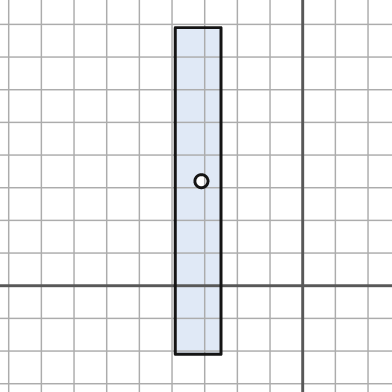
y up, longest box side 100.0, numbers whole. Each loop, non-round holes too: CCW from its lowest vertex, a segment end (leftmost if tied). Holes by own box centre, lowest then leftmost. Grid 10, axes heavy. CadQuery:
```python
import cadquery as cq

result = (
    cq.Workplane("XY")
    .moveTo(-39.0, -21.0)
    .lineTo(-25.0, -21.0)
    .lineTo(-25.0, 79.0)
    .lineTo(-39.0, 79.0)
    .close()
    .moveTo(-31.0, 32.0)
    .circle(2.0)
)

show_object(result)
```